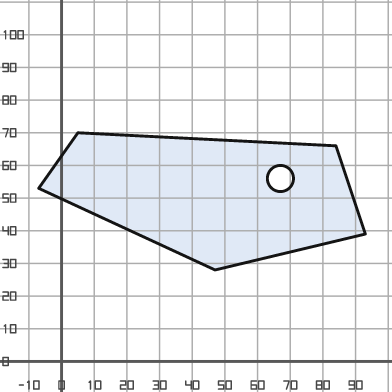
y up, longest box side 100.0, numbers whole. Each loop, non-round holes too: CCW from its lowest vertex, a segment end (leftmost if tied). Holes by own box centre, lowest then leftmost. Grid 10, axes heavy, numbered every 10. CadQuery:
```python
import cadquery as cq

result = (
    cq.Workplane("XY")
    .moveTo(47.0, 28.0)
    .lineTo(93.0, 39.0)
    .lineTo(84.0, 66.0)
    .lineTo(5.0, 70.0)
    .lineTo(-7.0, 53.0)
    .close()
    .moveTo(67.0, 56.0)
    .circle(4.0)
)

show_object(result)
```